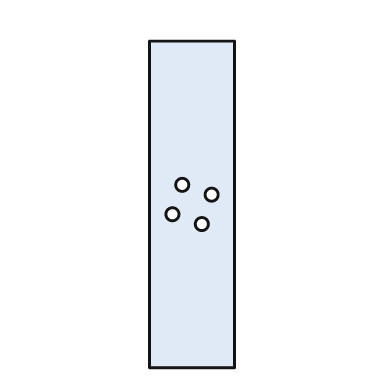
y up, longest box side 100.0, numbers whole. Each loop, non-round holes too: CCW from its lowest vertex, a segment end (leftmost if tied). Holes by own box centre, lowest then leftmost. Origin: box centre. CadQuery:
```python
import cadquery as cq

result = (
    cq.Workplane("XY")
    .moveTo(-13.0, -50.0)
    .lineTo(13.0, -50.0)
    .lineTo(13.0, 50.0)
    .lineTo(-13.0, 50.0)
    .close()
    .moveTo(3.0, -6.0)
    .circle(2.0)
    .moveTo(-6.0, -3.0)
    .circle(2.0)
    .moveTo(6.0, 3.0)
    .circle(2.0)
    .moveTo(-3.0, 6.0)
    .circle(2.0)
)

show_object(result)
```